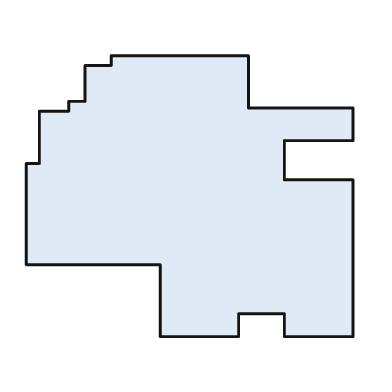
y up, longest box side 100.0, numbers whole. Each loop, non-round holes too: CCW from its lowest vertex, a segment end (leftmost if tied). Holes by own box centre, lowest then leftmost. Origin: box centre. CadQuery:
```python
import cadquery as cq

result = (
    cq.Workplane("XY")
    .moveTo(-9.0, -43.0)
    .lineTo(15.0, -43.0)
    .lineTo(15.0, -36.0)
    .lineTo(29.0, -36.0)
    .lineTo(29.0, -43.0)
    .lineTo(50.0, -43.0)
    .lineTo(50.0, 5.0)
    .lineTo(29.0, 5.0)
    .lineTo(29.0, 17.0)
    .lineTo(50.0, 17.0)
    .lineTo(50.0, 27.0)
    .lineTo(18.0, 27.0)
    .lineTo(18.0, 43.0)
    .lineTo(-24.0, 43.0)
    .lineTo(-24.0, 40.0)
    .lineTo(-32.0, 40.0)
    .lineTo(-32.0, 29.0)
    .lineTo(-37.0, 29.0)
    .lineTo(-37.0, 26.0)
    .lineTo(-46.0, 26.0)
    .lineTo(-46.0, 10.0)
    .lineTo(-50.0, 10.0)
    .lineTo(-50.0, -21.0)
    .lineTo(-9.0, -21.0)
    .close()
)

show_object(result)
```